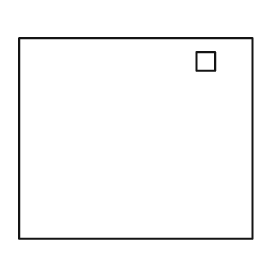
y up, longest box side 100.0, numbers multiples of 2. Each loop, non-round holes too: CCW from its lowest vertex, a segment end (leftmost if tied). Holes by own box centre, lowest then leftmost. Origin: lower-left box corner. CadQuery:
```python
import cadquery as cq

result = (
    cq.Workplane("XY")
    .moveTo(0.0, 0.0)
    .lineTo(100.0, 0.0)
    .lineTo(100.0, 86.0)
    .lineTo(0.0, 86.0)
    .close()
    .moveTo(76.0, 72.0)
    .lineTo(84.0, 72.0)
    .lineTo(84.0, 80.0)
    .lineTo(76.0, 80.0)
    .close()
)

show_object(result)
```